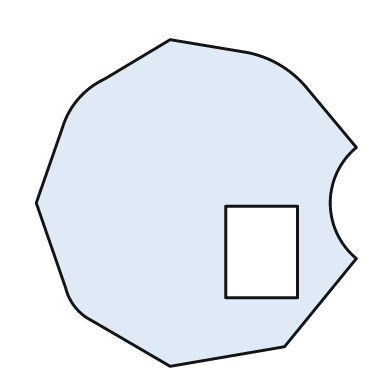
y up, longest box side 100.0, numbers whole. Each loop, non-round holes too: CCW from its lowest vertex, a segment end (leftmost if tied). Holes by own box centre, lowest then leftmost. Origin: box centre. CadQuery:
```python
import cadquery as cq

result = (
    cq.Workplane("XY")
    .moveTo(-8.0, -50.0)
    .lineTo(27.0, -44.0)
    .lineTo(49.0, -17.0)
    .threePointArc((41.0, 0.0), (49.0, 17.0))
    .lineTo(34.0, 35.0)
    .threePointArc((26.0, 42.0), (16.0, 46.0))
    .lineTo(-8.0, 50.0)
    .lineTo(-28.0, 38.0)
    .threePointArc((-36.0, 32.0), (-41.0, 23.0))
    .lineTo(-49.0, 0.0)
    .lineTo(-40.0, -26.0)
    .threePointArc((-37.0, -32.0), (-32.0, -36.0))
    .close()
    .moveTo(9.0, -29.0)
    .lineTo(31.0, -29.0)
    .lineTo(31.0, -1.0)
    .lineTo(9.0, -1.0)
    .close()
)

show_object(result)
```